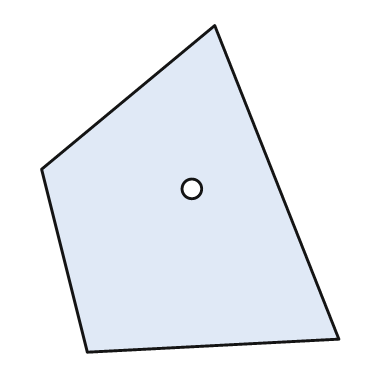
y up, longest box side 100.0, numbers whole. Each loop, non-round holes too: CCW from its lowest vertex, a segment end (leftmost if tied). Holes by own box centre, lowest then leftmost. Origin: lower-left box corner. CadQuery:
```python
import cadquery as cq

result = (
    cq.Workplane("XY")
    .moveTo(14.0, 0.0)
    .lineTo(91.0, 4.0)
    .lineTo(53.0, 100.0)
    .lineTo(0.0, 56.0)
    .close()
    .moveTo(46.0, 50.0)
    .circle(3.0)
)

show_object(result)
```